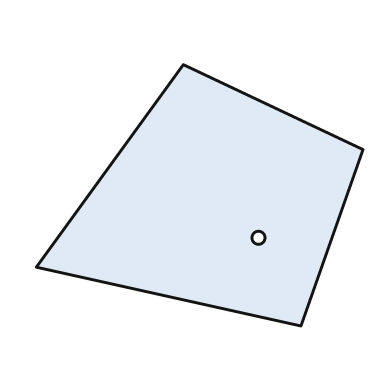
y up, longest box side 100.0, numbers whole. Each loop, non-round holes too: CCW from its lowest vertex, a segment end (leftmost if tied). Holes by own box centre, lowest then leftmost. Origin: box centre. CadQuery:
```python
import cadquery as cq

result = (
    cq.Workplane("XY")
    .moveTo(31.0, -40.0)
    .lineTo(50.0, 14.0)
    .lineTo(-5.0, 40.0)
    .lineTo(-50.0, -22.0)
    .close()
    .moveTo(18.0, -13.0)
    .circle(2.0)
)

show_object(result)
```